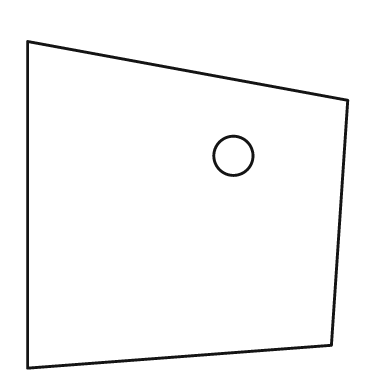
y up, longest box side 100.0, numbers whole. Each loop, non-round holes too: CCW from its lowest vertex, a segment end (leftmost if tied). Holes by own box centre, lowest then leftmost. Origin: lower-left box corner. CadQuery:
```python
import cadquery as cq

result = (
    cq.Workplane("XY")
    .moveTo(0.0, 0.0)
    .lineTo(93.0, 7.0)
    .lineTo(98.0, 82.0)
    .lineTo(0.0, 100.0)
    .close()
    .moveTo(63.0, 65.0)
    .circle(6.0)
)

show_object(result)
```